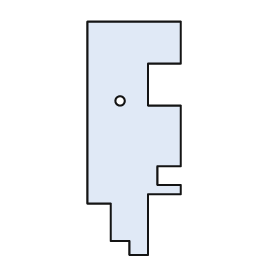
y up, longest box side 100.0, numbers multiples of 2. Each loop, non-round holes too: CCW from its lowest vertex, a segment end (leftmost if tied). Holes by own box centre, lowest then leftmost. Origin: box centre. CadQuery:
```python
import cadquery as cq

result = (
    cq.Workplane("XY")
    .moveTo(-2.0, -50.0)
    .lineTo(6.0, -50.0)
    .lineTo(6.0, -24.0)
    .lineTo(20.0, -24.0)
    .lineTo(20.0, -20.0)
    .lineTo(10.0, -20.0)
    .lineTo(10.0, -12.0)
    .lineTo(20.0, -12.0)
    .lineTo(20.0, 14.0)
    .lineTo(6.0, 14.0)
    .lineTo(6.0, 32.0)
    .lineTo(20.0, 32.0)
    .lineTo(20.0, 50.0)
    .lineTo(-20.0, 50.0)
    .lineTo(-20.0, -28.0)
    .lineTo(-10.0, -28.0)
    .lineTo(-10.0, -44.0)
    .lineTo(-2.0, -44.0)
    .close()
    .moveTo(-6.0, 16.0)
    .circle(2.0)
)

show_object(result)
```